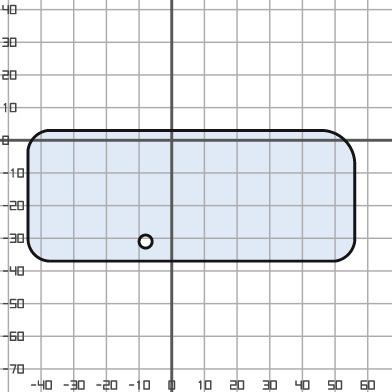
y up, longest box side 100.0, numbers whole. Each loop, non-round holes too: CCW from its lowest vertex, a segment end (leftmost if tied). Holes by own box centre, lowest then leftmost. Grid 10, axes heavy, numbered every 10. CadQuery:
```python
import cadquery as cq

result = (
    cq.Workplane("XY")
    .moveTo(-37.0, -37.0)
    .lineTo(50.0, -37.0)
    .threePointArc((54.0, -35.0), (56.0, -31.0))
    .lineTo(56.0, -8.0)
    .threePointArc((53.0, 0.0), (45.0, 3.0))
    .lineTo(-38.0, 3.0)
    .threePointArc((-42.0, 1.0), (-44.0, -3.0))
    .lineTo(-44.0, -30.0)
    .threePointArc((-42.0, -35.0), (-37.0, -37.0))
    .close()
    .moveTo(-8.0, -31.0)
    .circle(2.0)
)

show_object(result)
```